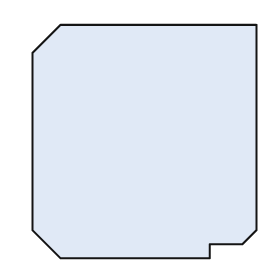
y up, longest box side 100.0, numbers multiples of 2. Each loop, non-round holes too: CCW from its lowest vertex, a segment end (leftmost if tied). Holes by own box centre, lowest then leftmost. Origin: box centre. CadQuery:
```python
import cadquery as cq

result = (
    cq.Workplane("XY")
    .moveTo(-36.0, -50.0)
    .lineTo(28.0, -50.0)
    .lineTo(28.0, -44.0)
    .lineTo(42.0, -44.0)
    .lineTo(48.0, -38.0)
    .lineTo(48.0, 50.0)
    .lineTo(-36.0, 50.0)
    .lineTo(-48.0, 38.0)
    .lineTo(-48.0, -38.0)
    .close()
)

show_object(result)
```